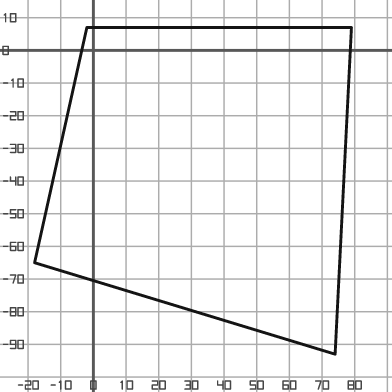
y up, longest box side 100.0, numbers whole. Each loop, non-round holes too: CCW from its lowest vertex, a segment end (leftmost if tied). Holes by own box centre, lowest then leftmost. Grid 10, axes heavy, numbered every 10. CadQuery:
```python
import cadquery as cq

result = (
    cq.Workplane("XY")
    .moveTo(74.0, -93.0)
    .lineTo(79.0, 7.0)
    .lineTo(-2.0, 7.0)
    .lineTo(-18.0, -65.0)
    .close()
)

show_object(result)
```